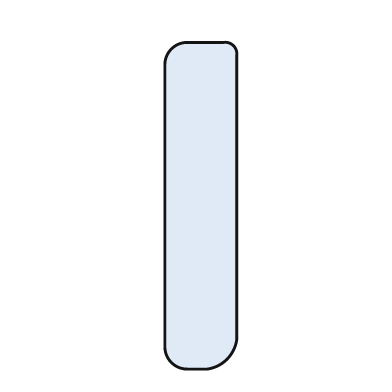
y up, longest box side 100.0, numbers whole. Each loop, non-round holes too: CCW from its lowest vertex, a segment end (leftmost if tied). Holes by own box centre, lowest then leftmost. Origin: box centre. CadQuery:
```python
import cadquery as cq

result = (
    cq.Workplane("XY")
    .moveTo(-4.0, -50.0)
    .lineTo(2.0, -50.0)
    .threePointArc((8.0, -47.0), (11.0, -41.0))
    .lineTo(11.0, 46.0)
    .threePointArc((10.0, 49.0), (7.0, 50.0))
    .lineTo(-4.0, 50.0)
    .threePointArc((-9.0, 48.0), (-11.0, 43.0))
    .lineTo(-11.0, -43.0)
    .threePointArc((-9.0, -48.0), (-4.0, -50.0))
    .close()
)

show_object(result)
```